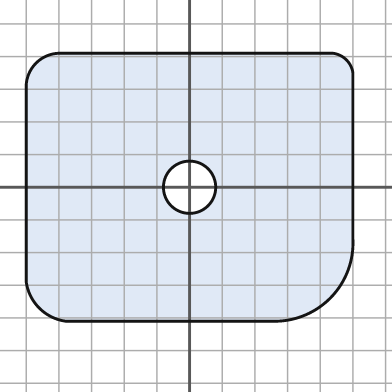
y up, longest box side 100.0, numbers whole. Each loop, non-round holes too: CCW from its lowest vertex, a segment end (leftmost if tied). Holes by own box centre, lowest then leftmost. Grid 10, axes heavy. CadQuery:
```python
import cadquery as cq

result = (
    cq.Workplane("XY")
    .moveTo(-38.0, -41.0)
    .lineTo(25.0, -41.0)
    .threePointArc((43.0, -34.0), (50.0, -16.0))
    .lineTo(50.0, 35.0)
    .threePointArc((48.0, 39.0), (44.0, 41.0))
    .lineTo(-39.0, 41.0)
    .threePointArc((-47.0, 38.0), (-50.0, 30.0))
    .lineTo(-50.0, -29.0)
    .threePointArc((-46.0, -37.0), (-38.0, -41.0))
    .close()
    .moveTo(0.0, 0.0)
    .circle(8.0)
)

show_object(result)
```